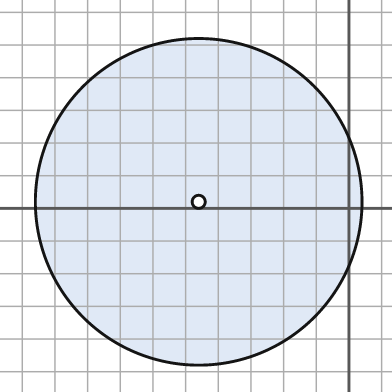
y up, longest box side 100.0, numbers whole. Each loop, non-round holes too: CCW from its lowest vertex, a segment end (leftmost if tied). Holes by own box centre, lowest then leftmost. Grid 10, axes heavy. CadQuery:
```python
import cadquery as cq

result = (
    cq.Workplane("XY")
    .moveTo(-46.0, 2.0)
    .circle(50.0)
    .moveTo(-46.0, 2.0)
    .circle(2.0)
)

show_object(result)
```